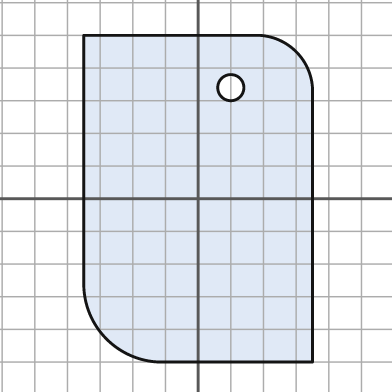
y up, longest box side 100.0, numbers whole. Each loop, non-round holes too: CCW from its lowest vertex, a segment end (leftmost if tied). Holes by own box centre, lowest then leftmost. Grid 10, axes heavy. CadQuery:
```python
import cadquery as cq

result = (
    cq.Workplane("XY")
    .moveTo(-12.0, -50.0)
    .lineTo(35.0, -50.0)
    .lineTo(35.0, 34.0)
    .threePointArc((30.0, 45.0), (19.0, 50.0))
    .lineTo(-35.0, 50.0)
    .lineTo(-35.0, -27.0)
    .threePointArc((-28.0, -43.0), (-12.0, -50.0))
    .close()
    .moveTo(10.0, 34.0)
    .circle(4.0)
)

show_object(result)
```